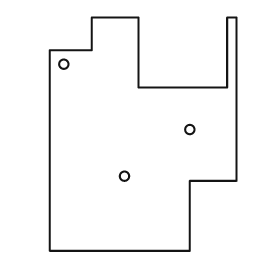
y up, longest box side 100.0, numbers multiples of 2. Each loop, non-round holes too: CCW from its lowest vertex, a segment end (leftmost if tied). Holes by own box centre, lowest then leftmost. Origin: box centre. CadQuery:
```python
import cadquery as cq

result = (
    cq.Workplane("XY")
    .moveTo(-40.0, -50.0)
    .lineTo(20.0, -50.0)
    .lineTo(20.0, -20.0)
    .lineTo(40.0, -20.0)
    .lineTo(40.0, 50.0)
    .lineTo(36.0, 50.0)
    .lineTo(36.0, 20.0)
    .lineTo(-2.0, 20.0)
    .lineTo(-2.0, 50.0)
    .lineTo(-22.0, 50.0)
    .lineTo(-22.0, 36.0)
    .lineTo(-40.0, 36.0)
    .close()
    .moveTo(-8.0, -18.0)
    .circle(2.0)
    .moveTo(20.0, 2.0)
    .circle(2.0)
    .moveTo(-34.0, 30.0)
    .circle(2.0)
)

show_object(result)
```